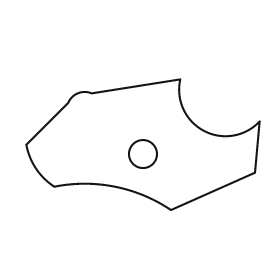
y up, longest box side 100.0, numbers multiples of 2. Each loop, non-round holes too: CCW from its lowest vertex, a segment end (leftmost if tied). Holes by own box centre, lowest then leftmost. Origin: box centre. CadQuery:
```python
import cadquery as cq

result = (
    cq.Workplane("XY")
    .moveTo(12.0, -28.0)
    .lineTo(48.0, -12.0)
    .lineTo(50.0, 10.0)
    .threePointArc((26.0, 6.0), (16.0, 28.0))
    .lineTo(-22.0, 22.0)
    .threePointArc((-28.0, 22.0), (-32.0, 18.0))
    .lineTo(-50.0, 0.0)
    .threePointArc((-46.0, -10.0), (-38.0, -18.0))
    .threePointArc((-12.0, -18.0), (12.0, -28.0))
    .close()
    .moveTo(0.0, -4.0)
    .circle(6.0)
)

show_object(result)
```